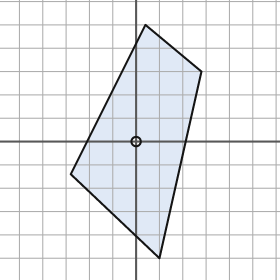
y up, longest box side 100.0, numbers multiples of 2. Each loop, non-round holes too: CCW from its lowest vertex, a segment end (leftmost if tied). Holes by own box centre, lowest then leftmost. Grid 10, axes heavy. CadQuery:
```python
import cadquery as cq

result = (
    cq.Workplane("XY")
    .moveTo(10.0, -50.0)
    .lineTo(28.0, 30.0)
    .lineTo(4.0, 50.0)
    .lineTo(-28.0, -14.0)
    .close()
    .moveTo(0.0, 0.0)
    .circle(2.0)
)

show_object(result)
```